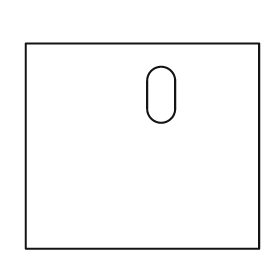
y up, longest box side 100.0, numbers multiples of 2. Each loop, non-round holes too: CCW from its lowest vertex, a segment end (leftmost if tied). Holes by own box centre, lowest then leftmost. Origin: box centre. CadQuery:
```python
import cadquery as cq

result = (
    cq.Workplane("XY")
    .moveTo(-50.0, -44.0)
    .lineTo(50.0, -44.0)
    .lineTo(50.0, 44.0)
    .lineTo(-50.0, 44.0)
    .close()
    .moveTo(2.0, 16.0)
    .threePointArc((8.0, 10.0), (14.0, 16.0))
    .lineTo(14.0, 28.0)
    .threePointArc((8.0, 34.0), (2.0, 28.0))
    .close()
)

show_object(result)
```